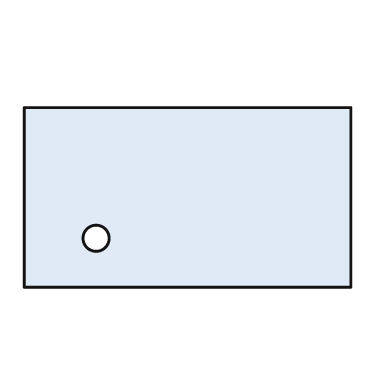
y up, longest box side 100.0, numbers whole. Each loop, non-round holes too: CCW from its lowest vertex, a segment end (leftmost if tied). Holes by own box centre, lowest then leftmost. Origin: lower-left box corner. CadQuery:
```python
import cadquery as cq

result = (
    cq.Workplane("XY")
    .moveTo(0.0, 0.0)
    .lineTo(100.0, 0.0)
    .lineTo(100.0, 55.0)
    .lineTo(0.0, 55.0)
    .close()
    .moveTo(22.0, 15.0)
    .circle(4.0)
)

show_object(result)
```